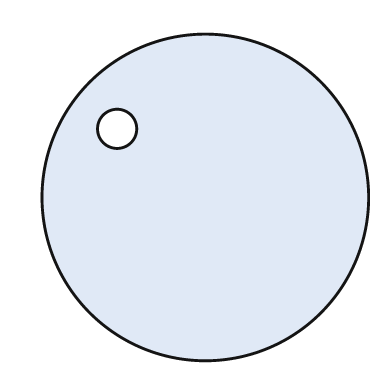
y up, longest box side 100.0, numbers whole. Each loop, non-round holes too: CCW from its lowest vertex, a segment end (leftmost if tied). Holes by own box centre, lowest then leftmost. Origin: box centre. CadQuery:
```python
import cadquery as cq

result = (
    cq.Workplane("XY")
    .moveTo(0.0, 0.0)
    .circle(50.0)
    .moveTo(-27.0, 21.0)
    .circle(6.0)
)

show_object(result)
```